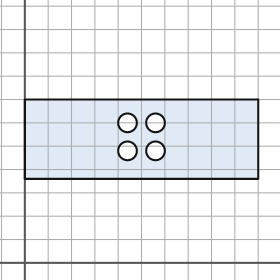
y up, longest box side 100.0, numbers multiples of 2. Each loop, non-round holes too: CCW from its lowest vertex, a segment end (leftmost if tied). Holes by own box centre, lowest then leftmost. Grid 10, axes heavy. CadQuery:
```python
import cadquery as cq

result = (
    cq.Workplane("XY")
    .moveTo(0.0, 36.0)
    .lineTo(100.0, 36.0)
    .lineTo(100.0, 70.0)
    .lineTo(0.0, 70.0)
    .close()
    .moveTo(44.0, 48.0)
    .circle(4.0)
    .moveTo(56.0, 48.0)
    .circle(4.0)
    .moveTo(44.0, 60.0)
    .circle(4.0)
    .moveTo(56.0, 60.0)
    .circle(4.0)
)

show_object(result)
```